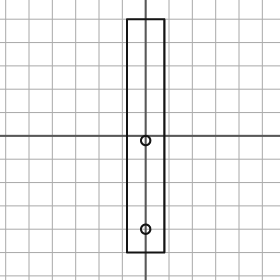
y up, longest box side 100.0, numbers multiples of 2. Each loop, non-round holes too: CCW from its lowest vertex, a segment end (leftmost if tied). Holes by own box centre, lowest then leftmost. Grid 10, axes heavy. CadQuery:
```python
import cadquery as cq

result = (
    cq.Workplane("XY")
    .moveTo(-8.0, -50.0)
    .lineTo(8.0, -50.0)
    .lineTo(8.0, 50.0)
    .lineTo(-8.0, 50.0)
    .close()
    .moveTo(0.0, -40.0)
    .circle(2.0)
    .moveTo(0.0, -2.0)
    .circle(2.0)
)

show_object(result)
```